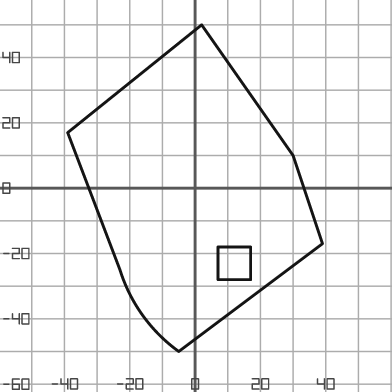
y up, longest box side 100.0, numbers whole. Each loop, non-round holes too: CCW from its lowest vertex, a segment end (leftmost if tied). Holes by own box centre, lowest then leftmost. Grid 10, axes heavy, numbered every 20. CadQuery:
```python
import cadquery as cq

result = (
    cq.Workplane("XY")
    .moveTo(-5.0, -50.0)
    .lineTo(39.0, -17.0)
    .lineTo(30.0, 10.0)
    .lineTo(2.0, 50.0)
    .lineTo(-39.0, 17.0)
    .lineTo(-23.0, -25.0)
    .threePointArc((-16.0, -39.0), (-5.0, -50.0))
    .close()
    .moveTo(7.0, -28.0)
    .lineTo(17.0, -28.0)
    .lineTo(17.0, -18.0)
    .lineTo(7.0, -18.0)
    .close()
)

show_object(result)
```